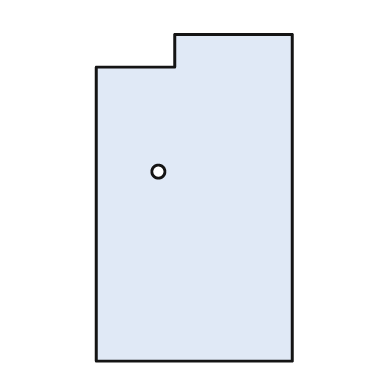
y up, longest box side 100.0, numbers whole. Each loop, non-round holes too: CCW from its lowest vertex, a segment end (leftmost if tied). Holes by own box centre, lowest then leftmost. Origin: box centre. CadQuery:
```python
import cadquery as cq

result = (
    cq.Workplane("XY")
    .moveTo(-30.0, -50.0)
    .lineTo(30.0, -50.0)
    .lineTo(30.0, 50.0)
    .lineTo(-6.0, 50.0)
    .lineTo(-6.0, 40.0)
    .lineTo(-30.0, 40.0)
    .close()
    .moveTo(-11.0, 8.0)
    .circle(2.0)
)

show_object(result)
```